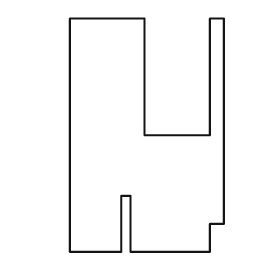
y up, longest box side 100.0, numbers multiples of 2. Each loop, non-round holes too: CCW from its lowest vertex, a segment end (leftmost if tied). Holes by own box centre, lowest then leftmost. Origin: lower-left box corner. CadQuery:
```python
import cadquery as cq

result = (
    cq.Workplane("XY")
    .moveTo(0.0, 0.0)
    .lineTo(22.0, 0.0)
    .lineTo(22.0, 24.0)
    .lineTo(26.0, 24.0)
    .lineTo(26.0, 0.0)
    .lineTo(60.0, 0.0)
    .lineTo(60.0, 12.0)
    .lineTo(66.0, 12.0)
    .lineTo(66.0, 100.0)
    .lineTo(60.0, 100.0)
    .lineTo(60.0, 50.0)
    .lineTo(32.0, 50.0)
    .lineTo(32.0, 100.0)
    .lineTo(0.0, 100.0)
    .close()
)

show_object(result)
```